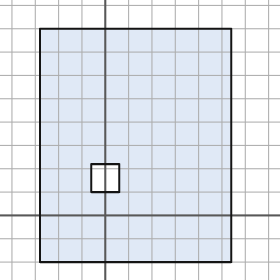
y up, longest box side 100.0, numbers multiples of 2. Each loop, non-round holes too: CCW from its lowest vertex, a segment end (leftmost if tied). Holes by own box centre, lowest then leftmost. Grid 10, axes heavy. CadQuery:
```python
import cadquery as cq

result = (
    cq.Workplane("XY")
    .moveTo(-28.0, -20.0)
    .lineTo(54.0, -20.0)
    .lineTo(54.0, 80.0)
    .lineTo(-28.0, 80.0)
    .close()
    .moveTo(-6.0, 10.0)
    .lineTo(6.0, 10.0)
    .lineTo(6.0, 22.0)
    .lineTo(-6.0, 22.0)
    .close()
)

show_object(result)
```